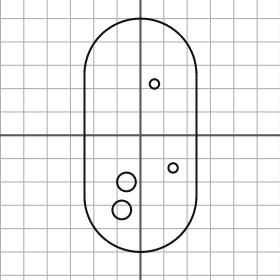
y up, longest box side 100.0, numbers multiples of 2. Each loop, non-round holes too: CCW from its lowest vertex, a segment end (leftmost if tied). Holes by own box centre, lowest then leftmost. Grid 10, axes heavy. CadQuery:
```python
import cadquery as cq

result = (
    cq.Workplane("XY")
    .moveTo(-24.0, -26.0)
    .threePointArc((0.0, -50.0), (24.0, -26.0))
    .lineTo(24.0, 26.0)
    .threePointArc((0.0, 50.0), (-24.0, 26.0))
    .close()
    .moveTo(-8.0, -32.0)
    .circle(4.0)
    .moveTo(-6.0, -20.0)
    .circle(4.0)
    .moveTo(14.0, -14.0)
    .circle(2.0)
    .moveTo(6.0, 22.0)
    .circle(2.0)
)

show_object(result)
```